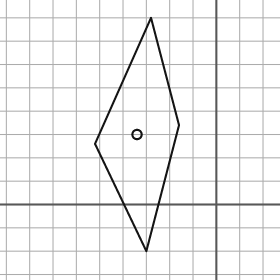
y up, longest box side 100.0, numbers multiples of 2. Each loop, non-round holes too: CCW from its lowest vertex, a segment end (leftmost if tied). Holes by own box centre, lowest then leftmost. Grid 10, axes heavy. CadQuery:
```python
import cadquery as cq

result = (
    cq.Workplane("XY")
    .moveTo(-30.0, -20.0)
    .lineTo(-16.0, 34.0)
    .lineTo(-28.0, 80.0)
    .lineTo(-52.0, 26.0)
    .close()
    .moveTo(-34.0, 30.0)
    .circle(2.0)
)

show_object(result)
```